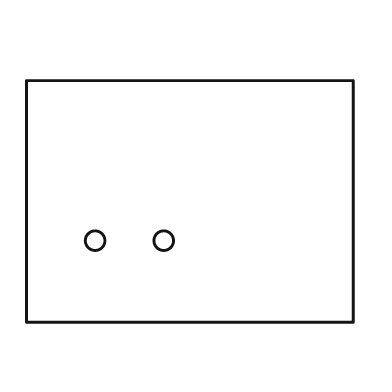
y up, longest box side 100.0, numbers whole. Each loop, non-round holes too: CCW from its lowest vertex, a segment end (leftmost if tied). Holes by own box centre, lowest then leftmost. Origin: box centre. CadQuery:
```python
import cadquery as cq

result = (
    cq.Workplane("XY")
    .moveTo(-50.0, -37.0)
    .lineTo(50.0, -37.0)
    .lineTo(50.0, 37.0)
    .lineTo(-50.0, 37.0)
    .close()
    .moveTo(-29.0, -12.0)
    .circle(3.0)
    .moveTo(-8.0, -12.0)
    .circle(3.0)
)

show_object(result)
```